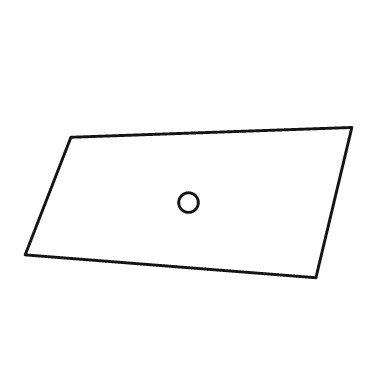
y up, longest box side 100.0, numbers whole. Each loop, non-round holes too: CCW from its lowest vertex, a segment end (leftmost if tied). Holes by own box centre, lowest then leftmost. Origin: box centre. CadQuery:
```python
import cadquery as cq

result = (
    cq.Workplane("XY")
    .moveTo(39.0, -23.0)
    .lineTo(50.0, 23.0)
    .lineTo(-36.0, 20.0)
    .lineTo(-50.0, -16.0)
    .close()
    .moveTo(0.0, 0.0)
    .circle(3.0)
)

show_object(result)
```